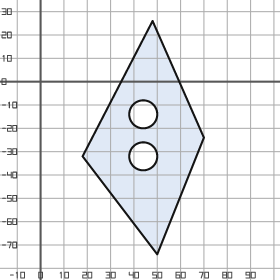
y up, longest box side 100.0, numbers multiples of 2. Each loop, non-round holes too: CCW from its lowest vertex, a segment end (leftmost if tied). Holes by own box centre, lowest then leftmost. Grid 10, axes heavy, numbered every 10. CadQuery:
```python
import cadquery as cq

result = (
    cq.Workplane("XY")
    .moveTo(50.0, -74.0)
    .lineTo(70.0, -24.0)
    .lineTo(48.0, 26.0)
    .lineTo(18.0, -32.0)
    .close()
    .moveTo(44.0, -32.0)
    .circle(6.0)
    .moveTo(44.0, -14.0)
    .circle(6.0)
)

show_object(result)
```